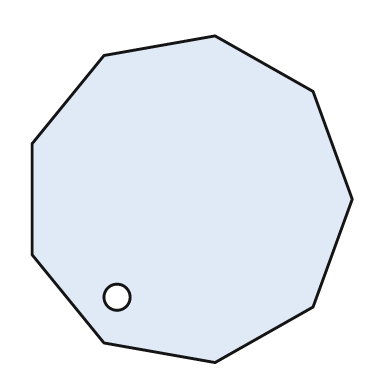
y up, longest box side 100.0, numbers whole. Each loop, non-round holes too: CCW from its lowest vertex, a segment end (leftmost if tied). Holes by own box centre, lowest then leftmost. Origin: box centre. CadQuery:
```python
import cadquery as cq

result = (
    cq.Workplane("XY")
    .moveTo(7.0, -50.0)
    .lineTo(37.0, -33.0)
    .lineTo(49.0, 0.0)
    .lineTo(37.0, 33.0)
    .lineTo(7.0, 50.0)
    .lineTo(-27.0, 44.0)
    .lineTo(-49.0, 17.0)
    .lineTo(-49.0, -17.0)
    .lineTo(-27.0, -44.0)
    .close()
    .moveTo(-23.0, -30.0)
    .circle(4.0)
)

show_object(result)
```